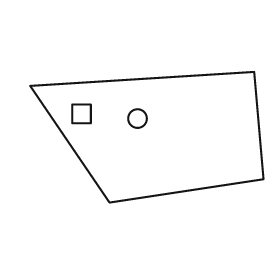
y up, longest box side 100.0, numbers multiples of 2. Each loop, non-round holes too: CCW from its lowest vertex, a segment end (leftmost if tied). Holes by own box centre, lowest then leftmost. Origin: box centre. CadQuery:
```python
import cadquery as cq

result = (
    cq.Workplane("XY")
    .moveTo(-16.0, -28.0)
    .lineTo(50.0, -18.0)
    .lineTo(46.0, 28.0)
    .lineTo(-50.0, 22.0)
    .close()
    .moveTo(-4.0, 8.0)
    .circle(4.0)
    .moveTo(-32.0, 6.0)
    .lineTo(-24.0, 6.0)
    .lineTo(-24.0, 14.0)
    .lineTo(-32.0, 14.0)
    .close()
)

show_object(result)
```